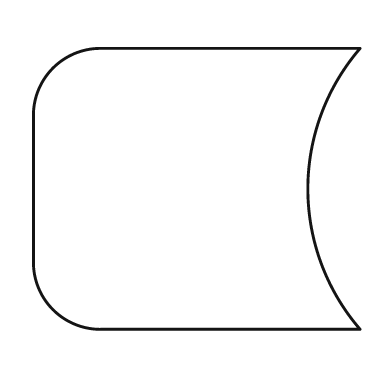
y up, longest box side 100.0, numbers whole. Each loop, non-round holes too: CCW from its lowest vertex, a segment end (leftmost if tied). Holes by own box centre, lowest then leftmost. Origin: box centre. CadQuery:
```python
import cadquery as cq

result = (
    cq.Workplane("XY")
    .moveTo(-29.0, -43.0)
    .lineTo(50.0, -43.0)
    .threePointArc((34.0, 0.0), (50.0, 43.0))
    .lineTo(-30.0, 43.0)
    .threePointArc((-44.0, 37.0), (-50.0, 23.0))
    .lineTo(-50.0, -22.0)
    .threePointArc((-44.0, -37.0), (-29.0, -43.0))
    .close()
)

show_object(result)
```